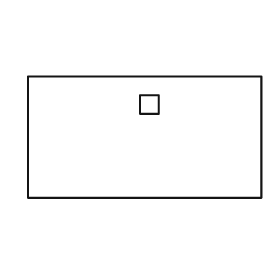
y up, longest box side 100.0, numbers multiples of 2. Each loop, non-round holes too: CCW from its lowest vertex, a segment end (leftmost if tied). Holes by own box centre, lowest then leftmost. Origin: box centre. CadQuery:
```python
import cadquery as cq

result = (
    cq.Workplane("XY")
    .moveTo(-50.0, -26.0)
    .lineTo(50.0, -26.0)
    .lineTo(50.0, 26.0)
    .lineTo(-50.0, 26.0)
    .close()
    .moveTo(-2.0, 10.0)
    .lineTo(6.0, 10.0)
    .lineTo(6.0, 18.0)
    .lineTo(-2.0, 18.0)
    .close()
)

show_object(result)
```